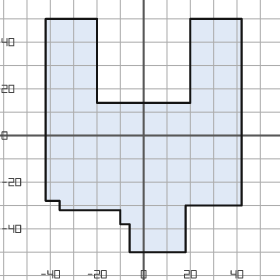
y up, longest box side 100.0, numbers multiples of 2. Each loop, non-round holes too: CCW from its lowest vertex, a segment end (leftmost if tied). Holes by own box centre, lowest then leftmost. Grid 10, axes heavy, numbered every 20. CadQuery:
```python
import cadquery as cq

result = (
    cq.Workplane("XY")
    .moveTo(-6.0, -50.0)
    .lineTo(18.0, -50.0)
    .lineTo(18.0, -30.0)
    .lineTo(42.0, -30.0)
    .lineTo(42.0, 50.0)
    .lineTo(20.0, 50.0)
    .lineTo(20.0, 14.0)
    .lineTo(-20.0, 14.0)
    .lineTo(-20.0, 50.0)
    .lineTo(-42.0, 50.0)
    .lineTo(-42.0, -28.0)
    .lineTo(-36.0, -28.0)
    .lineTo(-36.0, -32.0)
    .lineTo(-10.0, -32.0)
    .lineTo(-10.0, -38.0)
    .lineTo(-6.0, -38.0)
    .close()
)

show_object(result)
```